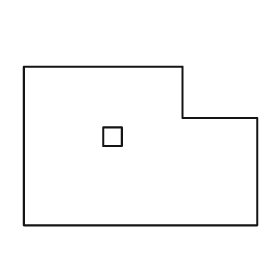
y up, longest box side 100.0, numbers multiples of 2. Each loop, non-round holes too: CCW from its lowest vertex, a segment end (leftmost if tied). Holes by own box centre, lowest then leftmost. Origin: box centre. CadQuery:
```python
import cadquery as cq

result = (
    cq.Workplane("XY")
    .moveTo(-50.0, -34.0)
    .lineTo(50.0, -34.0)
    .lineTo(50.0, 12.0)
    .lineTo(18.0, 12.0)
    .lineTo(18.0, 34.0)
    .lineTo(-50.0, 34.0)
    .close()
    .moveTo(-16.0, 0.0)
    .lineTo(-8.0, 0.0)
    .lineTo(-8.0, 8.0)
    .lineTo(-16.0, 8.0)
    .close()
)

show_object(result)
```